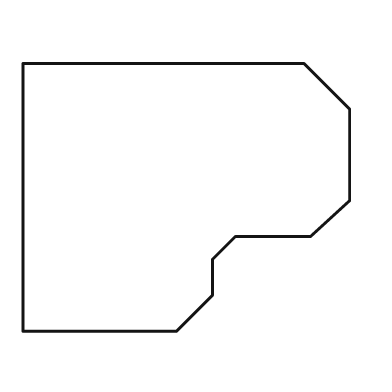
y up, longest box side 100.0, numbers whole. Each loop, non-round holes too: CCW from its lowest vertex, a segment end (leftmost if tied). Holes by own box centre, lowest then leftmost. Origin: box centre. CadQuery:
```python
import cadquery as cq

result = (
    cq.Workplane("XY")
    .moveTo(-50.0, -41.0)
    .lineTo(-3.0, -41.0)
    .lineTo(8.0, -30.0)
    .lineTo(8.0, -19.0)
    .lineTo(15.0, -12.0)
    .lineTo(38.0, -12.0)
    .lineTo(50.0, -1.0)
    .lineTo(50.0, 27.0)
    .lineTo(36.0, 41.0)
    .lineTo(-50.0, 41.0)
    .close()
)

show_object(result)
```